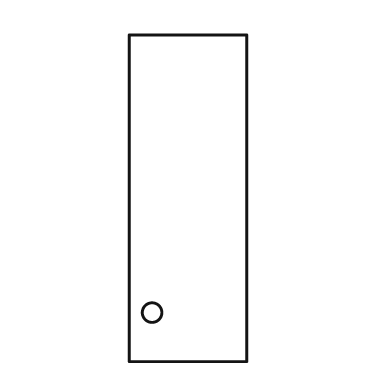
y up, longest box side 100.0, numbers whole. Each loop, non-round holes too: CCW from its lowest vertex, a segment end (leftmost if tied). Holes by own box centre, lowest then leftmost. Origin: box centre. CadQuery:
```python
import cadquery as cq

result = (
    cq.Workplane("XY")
    .moveTo(-18.0, -50.0)
    .lineTo(18.0, -50.0)
    .lineTo(18.0, 50.0)
    .lineTo(-18.0, 50.0)
    .close()
    .moveTo(-11.0, -35.0)
    .circle(3.0)
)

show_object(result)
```